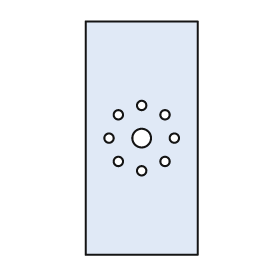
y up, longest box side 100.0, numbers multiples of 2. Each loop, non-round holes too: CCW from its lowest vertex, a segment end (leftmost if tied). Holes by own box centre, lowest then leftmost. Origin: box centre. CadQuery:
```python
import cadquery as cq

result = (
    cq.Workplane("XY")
    .moveTo(-24.0, -50.0)
    .lineTo(24.0, -50.0)
    .lineTo(24.0, 50.0)
    .lineTo(-24.0, 50.0)
    .close()
    .moveTo(0.0, -14.0)
    .circle(2.0)
    .moveTo(-10.0, -10.0)
    .circle(2.0)
    .moveTo(10.0, -10.0)
    .circle(2.0)
    .moveTo(-14.0, 0.0)
    .circle(2.0)
    .moveTo(0.0, 0.0)
    .circle(4.0)
    .moveTo(14.0, 0.0)
    .circle(2.0)
    .moveTo(-10.0, 10.0)
    .circle(2.0)
    .moveTo(10.0, 10.0)
    .circle(2.0)
    .moveTo(0.0, 14.0)
    .circle(2.0)
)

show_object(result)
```